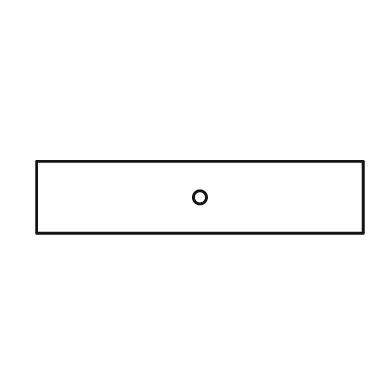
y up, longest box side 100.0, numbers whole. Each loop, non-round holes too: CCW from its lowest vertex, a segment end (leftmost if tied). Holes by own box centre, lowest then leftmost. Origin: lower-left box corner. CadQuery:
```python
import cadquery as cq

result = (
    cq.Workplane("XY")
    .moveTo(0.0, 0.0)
    .lineTo(100.0, 0.0)
    .lineTo(100.0, 22.0)
    .lineTo(0.0, 22.0)
    .close()
    .moveTo(50.0, 11.0)
    .circle(2.0)
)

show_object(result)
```